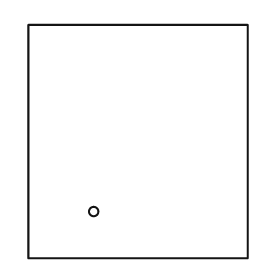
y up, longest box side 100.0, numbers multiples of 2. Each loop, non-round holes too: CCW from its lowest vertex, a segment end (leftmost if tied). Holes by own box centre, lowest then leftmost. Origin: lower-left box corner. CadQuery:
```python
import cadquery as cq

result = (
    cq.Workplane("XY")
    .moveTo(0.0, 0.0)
    .lineTo(94.0, 0.0)
    .lineTo(94.0, 100.0)
    .lineTo(0.0, 100.0)
    .close()
    .moveTo(28.0, 20.0)
    .circle(2.0)
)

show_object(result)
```